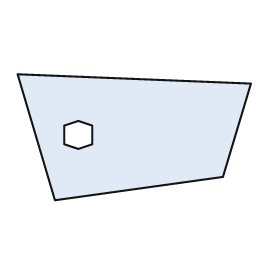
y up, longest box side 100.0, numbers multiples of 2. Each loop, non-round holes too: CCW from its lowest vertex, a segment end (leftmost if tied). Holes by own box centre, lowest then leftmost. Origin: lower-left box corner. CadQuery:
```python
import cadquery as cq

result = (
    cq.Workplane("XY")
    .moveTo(16.0, 0.0)
    .lineTo(88.0, 10.0)
    .lineTo(100.0, 50.0)
    .lineTo(0.0, 54.0)
    .close()
    .moveTo(26.0, 22.0)
    .lineTo(32.0, 24.0)
    .lineTo(32.0, 32.0)
    .lineTo(26.0, 34.0)
    .lineTo(20.0, 32.0)
    .lineTo(20.0, 24.0)
    .close()
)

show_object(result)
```